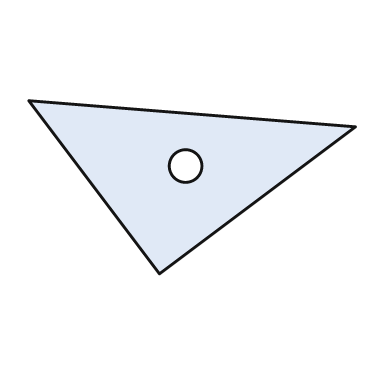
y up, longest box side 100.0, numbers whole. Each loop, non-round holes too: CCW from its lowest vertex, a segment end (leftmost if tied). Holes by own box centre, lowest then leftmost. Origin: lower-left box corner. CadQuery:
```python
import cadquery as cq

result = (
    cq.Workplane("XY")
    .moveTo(40.0, 0.0)
    .lineTo(100.0, 45.0)
    .lineTo(0.0, 53.0)
    .close()
    .moveTo(48.0, 33.0)
    .circle(5.0)
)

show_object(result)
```